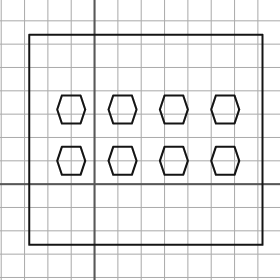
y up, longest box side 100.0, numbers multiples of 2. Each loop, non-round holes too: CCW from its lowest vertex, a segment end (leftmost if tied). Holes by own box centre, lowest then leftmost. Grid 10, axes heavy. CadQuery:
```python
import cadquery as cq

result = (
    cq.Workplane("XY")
    .moveTo(-28.0, -26.0)
    .lineTo(72.0, -26.0)
    .lineTo(72.0, 64.0)
    .lineTo(-28.0, 64.0)
    .close()
    .moveTo(-14.0, 4.0)
    .lineTo(-6.0, 4.0)
    .lineTo(-4.0, 10.0)
    .lineTo(-6.0, 16.0)
    .lineTo(-14.0, 16.0)
    .lineTo(-16.0, 10.0)
    .close()
    .moveTo(8.0, 4.0)
    .lineTo(16.0, 4.0)
    .lineTo(18.0, 10.0)
    .lineTo(16.0, 16.0)
    .lineTo(8.0, 16.0)
    .lineTo(6.0, 10.0)
    .close()
    .moveTo(30.0, 4.0)
    .lineTo(38.0, 4.0)
    .lineTo(40.0, 10.0)
    .lineTo(38.0, 16.0)
    .lineTo(30.0, 16.0)
    .lineTo(28.0, 10.0)
    .close()
    .moveTo(52.0, 4.0)
    .lineTo(60.0, 4.0)
    .lineTo(62.0, 10.0)
    .lineTo(60.0, 16.0)
    .lineTo(52.0, 16.0)
    .lineTo(50.0, 10.0)
    .close()
    .moveTo(-14.0, 26.0)
    .lineTo(-6.0, 26.0)
    .lineTo(-4.0, 32.0)
    .lineTo(-6.0, 38.0)
    .lineTo(-14.0, 38.0)
    .lineTo(-16.0, 32.0)
    .close()
    .moveTo(8.0, 26.0)
    .lineTo(16.0, 26.0)
    .lineTo(18.0, 32.0)
    .lineTo(16.0, 38.0)
    .lineTo(8.0, 38.0)
    .lineTo(6.0, 32.0)
    .close()
    .moveTo(30.0, 26.0)
    .lineTo(38.0, 26.0)
    .lineTo(40.0, 32.0)
    .lineTo(38.0, 38.0)
    .lineTo(30.0, 38.0)
    .lineTo(28.0, 32.0)
    .close()
    .moveTo(52.0, 26.0)
    .lineTo(60.0, 26.0)
    .lineTo(62.0, 32.0)
    .lineTo(60.0, 38.0)
    .lineTo(52.0, 38.0)
    .lineTo(50.0, 32.0)
    .close()
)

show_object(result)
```